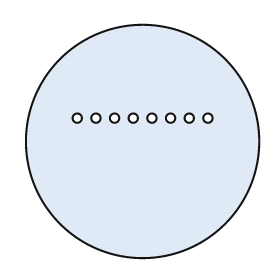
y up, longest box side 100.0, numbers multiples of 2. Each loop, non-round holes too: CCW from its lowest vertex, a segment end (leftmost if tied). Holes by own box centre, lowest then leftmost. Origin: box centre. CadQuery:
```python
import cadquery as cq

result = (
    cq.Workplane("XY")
    .moveTo(0.0, 0.0)
    .circle(50.0)
    .moveTo(-28.0, 10.0)
    .circle(2.0)
    .moveTo(-20.0, 10.0)
    .circle(2.0)
    .moveTo(-12.0, 10.0)
    .circle(2.0)
    .moveTo(-4.0, 10.0)
    .circle(2.0)
    .moveTo(4.0, 10.0)
    .circle(2.0)
    .moveTo(12.0, 10.0)
    .circle(2.0)
    .moveTo(20.0, 10.0)
    .circle(2.0)
    .moveTo(28.0, 10.0)
    .circle(2.0)
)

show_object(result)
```